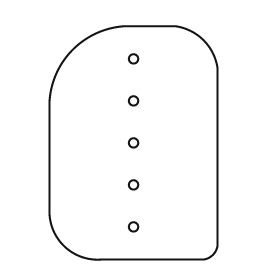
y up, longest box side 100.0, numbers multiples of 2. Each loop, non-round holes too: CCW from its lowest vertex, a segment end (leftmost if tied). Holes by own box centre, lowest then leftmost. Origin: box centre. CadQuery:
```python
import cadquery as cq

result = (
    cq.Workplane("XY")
    .moveTo(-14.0, -50.0)
    .lineTo(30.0, -50.0)
    .threePointArc((34.0, -48.0), (36.0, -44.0))
    .lineTo(36.0, 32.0)
    .threePointArc((30.0, 44.0), (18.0, 50.0))
    .lineTo(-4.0, 50.0)
    .threePointArc((-26.0, 40.0), (-36.0, 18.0))
    .lineTo(-36.0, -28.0)
    .threePointArc((-30.0, -44.0), (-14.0, -50.0))
    .close()
    .moveTo(0.0, -36.0)
    .circle(2.0)
    .moveTo(0.0, -18.0)
    .circle(2.0)
    .moveTo(0.0, 0.0)
    .circle(2.0)
    .moveTo(0.0, 18.0)
    .circle(2.0)
    .moveTo(0.0, 36.0)
    .circle(2.0)
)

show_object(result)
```